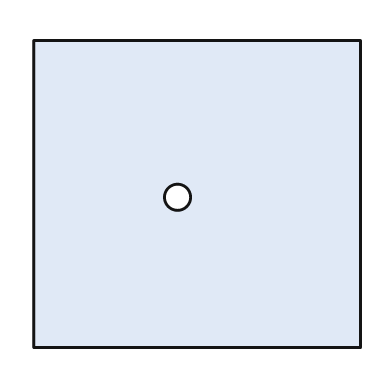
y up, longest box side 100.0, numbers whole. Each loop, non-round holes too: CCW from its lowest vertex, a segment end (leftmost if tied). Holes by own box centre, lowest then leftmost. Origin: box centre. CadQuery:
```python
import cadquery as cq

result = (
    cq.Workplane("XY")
    .moveTo(-50.0, -47.0)
    .lineTo(50.0, -47.0)
    .lineTo(50.0, 47.0)
    .lineTo(-50.0, 47.0)
    .close()
    .moveTo(-6.0, -1.0)
    .circle(4.0)
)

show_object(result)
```